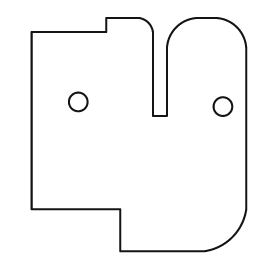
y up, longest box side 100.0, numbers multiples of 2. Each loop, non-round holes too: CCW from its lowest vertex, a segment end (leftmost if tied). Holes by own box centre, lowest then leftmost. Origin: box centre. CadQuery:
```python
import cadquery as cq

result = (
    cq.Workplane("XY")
    .moveTo(-8.0, -50.0)
    .lineTo(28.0, -50.0)
    .threePointArc((40.0, -44.0), (46.0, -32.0))
    .lineTo(46.0, 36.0)
    .threePointArc((42.0, 46.0), (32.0, 50.0))
    .lineTo(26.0, 50.0)
    .threePointArc((16.0, 46.0), (12.0, 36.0))
    .lineTo(12.0, 8.0)
    .lineTo(6.0, 8.0)
    .lineTo(6.0, 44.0)
    .threePointArc((4.0, 48.0), (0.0, 50.0))
    .lineTo(-14.0, 50.0)
    .lineTo(-14.0, 44.0)
    .lineTo(-46.0, 44.0)
    .lineTo(-46.0, -32.0)
    .lineTo(-8.0, -32.0)
    .close()
    .moveTo(36.0, 12.0)
    .circle(4.0)
    .moveTo(-26.0, 14.0)
    .circle(4.0)
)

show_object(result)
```